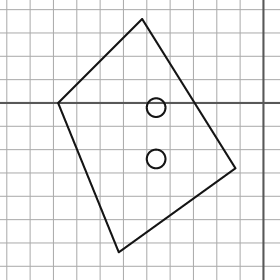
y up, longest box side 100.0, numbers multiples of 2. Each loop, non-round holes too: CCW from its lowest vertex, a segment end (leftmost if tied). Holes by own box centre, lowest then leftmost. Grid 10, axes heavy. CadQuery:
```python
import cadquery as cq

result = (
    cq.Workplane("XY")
    .moveTo(-62.0, -64.0)
    .lineTo(-12.0, -28.0)
    .lineTo(-52.0, 36.0)
    .lineTo(-88.0, 0.0)
    .close()
    .moveTo(-46.0, -24.0)
    .circle(4.0)
    .moveTo(-46.0, -2.0)
    .circle(4.0)
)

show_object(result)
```